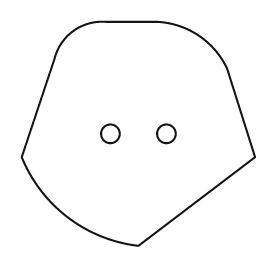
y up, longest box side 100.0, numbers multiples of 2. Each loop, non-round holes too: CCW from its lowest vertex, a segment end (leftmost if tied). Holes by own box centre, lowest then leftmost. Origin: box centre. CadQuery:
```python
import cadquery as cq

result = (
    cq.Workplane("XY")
    .moveTo(0.0, -48.0)
    .lineTo(50.0, -10.0)
    .lineTo(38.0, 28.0)
    .threePointArc((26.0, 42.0), (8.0, 48.0))
    .lineTo(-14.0, 48.0)
    .threePointArc((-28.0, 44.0), (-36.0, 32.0))
    .lineTo(-50.0, -10.0)
    .threePointArc((-30.0, -36.0), (0.0, -48.0))
    .close()
    .moveTo(-12.0, 0.0)
    .circle(4.0)
    .moveTo(12.0, 0.0)
    .circle(4.0)
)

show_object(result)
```